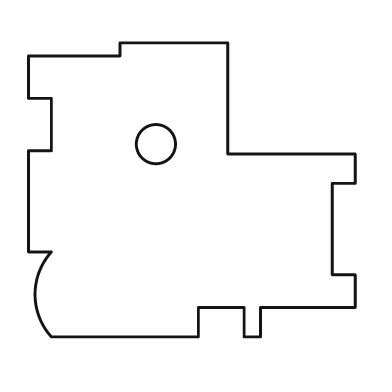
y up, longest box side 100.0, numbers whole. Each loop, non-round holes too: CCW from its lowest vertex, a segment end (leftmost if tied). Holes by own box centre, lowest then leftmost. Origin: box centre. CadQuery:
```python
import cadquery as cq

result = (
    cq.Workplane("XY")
    .moveTo(-43.0, -45.0)
    .lineTo(2.0, -45.0)
    .lineTo(2.0, -36.0)
    .lineTo(16.0, -36.0)
    .lineTo(16.0, -45.0)
    .lineTo(21.0, -45.0)
    .lineTo(21.0, -36.0)
    .lineTo(50.0, -36.0)
    .lineTo(50.0, -26.0)
    .lineTo(43.0, -26.0)
    .lineTo(43.0, 2.0)
    .lineTo(50.0, 2.0)
    .lineTo(50.0, 11.0)
    .lineTo(11.0, 11.0)
    .lineTo(11.0, 45.0)
    .lineTo(-22.0, 45.0)
    .lineTo(-22.0, 41.0)
    .lineTo(-50.0, 41.0)
    .lineTo(-50.0, 28.0)
    .lineTo(-43.0, 28.0)
    .lineTo(-43.0, 12.0)
    .lineTo(-50.0, 12.0)
    .lineTo(-50.0, -19.0)
    .lineTo(-43.0, -19.0)
    .threePointArc((-48.0, -32.0), (-43.0, -45.0))
    .close()
    .moveTo(-11.0, 14.0)
    .circle(6.0)
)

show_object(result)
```